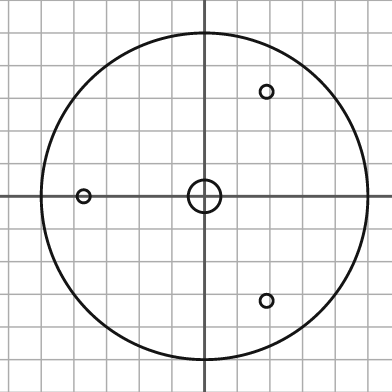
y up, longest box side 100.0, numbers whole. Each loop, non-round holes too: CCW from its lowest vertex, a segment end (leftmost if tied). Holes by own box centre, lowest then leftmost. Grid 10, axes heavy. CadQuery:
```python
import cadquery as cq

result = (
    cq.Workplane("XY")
    .moveTo(0.0, 0.0)
    .circle(50.0)
    .moveTo(19.0, -32.0)
    .circle(2.0)
    .moveTo(-37.0, 0.0)
    .circle(2.0)
    .moveTo(0.0, 0.0)
    .circle(5.0)
    .moveTo(19.0, 32.0)
    .circle(2.0)
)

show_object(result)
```